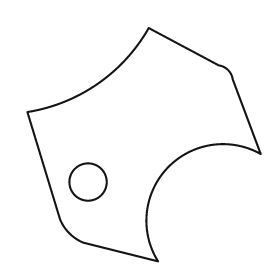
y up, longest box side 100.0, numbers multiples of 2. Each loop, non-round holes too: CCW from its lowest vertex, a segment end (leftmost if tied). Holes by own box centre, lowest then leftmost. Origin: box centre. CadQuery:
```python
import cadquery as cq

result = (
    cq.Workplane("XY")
    .moveTo(6.0, -50.0)
    .threePointArc((10.0, -10.0), (50.0, -4.0))
    .lineTo(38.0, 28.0)
    .threePointArc((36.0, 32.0), (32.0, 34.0))
    .lineTo(2.0, 50.0)
    .threePointArc((-20.0, 26.0), (-50.0, 14.0))
    .lineTo(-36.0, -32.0)
    .threePointArc((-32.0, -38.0), (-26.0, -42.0))
    .close()
    .moveTo(-24.0, -16.0)
    .circle(8.0)
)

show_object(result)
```